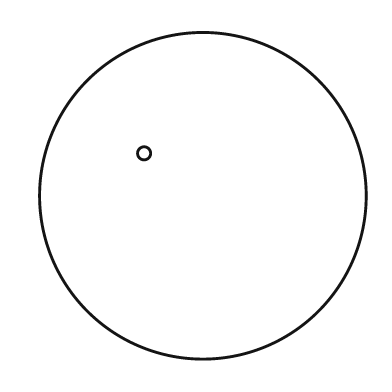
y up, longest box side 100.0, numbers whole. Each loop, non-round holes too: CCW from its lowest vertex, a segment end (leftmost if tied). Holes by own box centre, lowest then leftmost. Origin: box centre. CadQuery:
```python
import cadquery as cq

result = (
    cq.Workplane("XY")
    .moveTo(0.0, 0.0)
    .circle(50.0)
    .moveTo(-18.0, 13.0)
    .circle(2.0)
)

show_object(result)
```